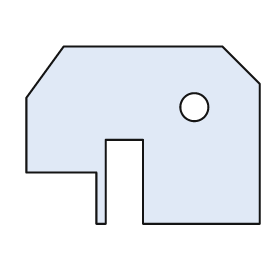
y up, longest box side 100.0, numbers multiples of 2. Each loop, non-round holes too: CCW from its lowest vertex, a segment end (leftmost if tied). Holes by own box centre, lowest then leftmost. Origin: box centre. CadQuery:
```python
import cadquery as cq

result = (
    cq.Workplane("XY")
    .moveTo(-20.0, -38.0)
    .lineTo(-16.0, -38.0)
    .lineTo(-16.0, -2.0)
    .lineTo(0.0, -2.0)
    .lineTo(0.0, -38.0)
    .lineTo(50.0, -38.0)
    .lineTo(50.0, 22.0)
    .lineTo(34.0, 38.0)
    .lineTo(-34.0, 38.0)
    .lineTo(-50.0, 16.0)
    .lineTo(-50.0, -16.0)
    .lineTo(-20.0, -16.0)
    .close()
    .moveTo(22.0, 12.0)
    .circle(6.0)
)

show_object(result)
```